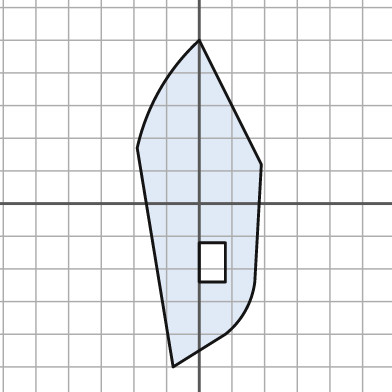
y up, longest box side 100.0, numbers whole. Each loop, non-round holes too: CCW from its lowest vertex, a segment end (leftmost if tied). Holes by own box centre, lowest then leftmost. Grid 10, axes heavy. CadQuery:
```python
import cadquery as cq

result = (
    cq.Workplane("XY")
    .moveTo(-8.0, -50.0)
    .lineTo(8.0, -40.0)
    .threePointArc((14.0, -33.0), (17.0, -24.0))
    .lineTo(19.0, 12.0)
    .lineTo(0.0, 50.0)
    .threePointArc((-12.0, 35.0), (-19.0, 17.0))
    .close()
    .moveTo(0.0, -24.0)
    .lineTo(8.0, -24.0)
    .lineTo(8.0, -12.0)
    .lineTo(0.0, -12.0)
    .close()
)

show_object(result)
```